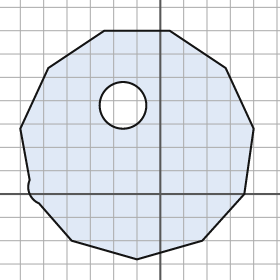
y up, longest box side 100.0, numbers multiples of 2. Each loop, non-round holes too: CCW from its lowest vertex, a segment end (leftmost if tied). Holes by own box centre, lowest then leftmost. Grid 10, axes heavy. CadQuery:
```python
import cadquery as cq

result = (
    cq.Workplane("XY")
    .moveTo(-10.0, -28.0)
    .lineTo(18.0, -20.0)
    .lineTo(36.0, 0.0)
    .lineTo(40.0, 28.0)
    .lineTo(28.0, 54.0)
    .lineTo(4.0, 70.0)
    .lineTo(-24.0, 70.0)
    .lineTo(-48.0, 54.0)
    .lineTo(-60.0, 28.0)
    .lineTo(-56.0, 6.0)
    .threePointArc((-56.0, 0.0), (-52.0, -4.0))
    .lineTo(-38.0, -20.0)
    .close()
    .moveTo(-16.0, 38.0)
    .circle(10.0)
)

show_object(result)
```